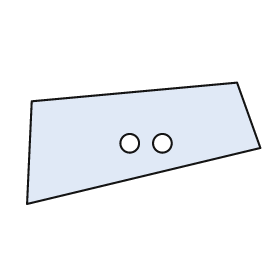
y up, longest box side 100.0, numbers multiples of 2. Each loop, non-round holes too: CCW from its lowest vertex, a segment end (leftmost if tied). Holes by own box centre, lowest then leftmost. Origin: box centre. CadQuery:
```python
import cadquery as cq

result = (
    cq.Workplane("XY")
    .moveTo(-50.0, -26.0)
    .lineTo(50.0, -2.0)
    .lineTo(40.0, 26.0)
    .lineTo(-48.0, 18.0)
    .close()
    .moveTo(-6.0, 0.0)
    .circle(4.0)
    .moveTo(8.0, 0.0)
    .circle(4.0)
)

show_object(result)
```